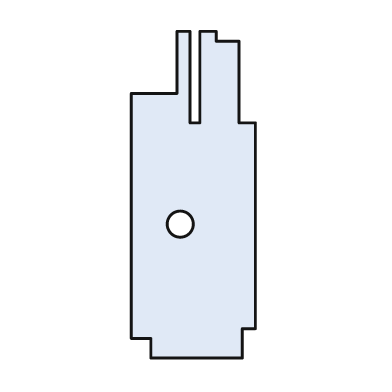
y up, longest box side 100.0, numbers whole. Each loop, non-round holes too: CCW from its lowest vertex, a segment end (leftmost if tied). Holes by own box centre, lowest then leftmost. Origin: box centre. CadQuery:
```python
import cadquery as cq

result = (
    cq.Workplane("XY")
    .moveTo(-13.0, -50.0)
    .lineTo(15.0, -50.0)
    .lineTo(15.0, -41.0)
    .lineTo(19.0, -41.0)
    .lineTo(19.0, 22.0)
    .lineTo(14.0, 22.0)
    .lineTo(14.0, 47.0)
    .lineTo(7.0, 47.0)
    .lineTo(7.0, 50.0)
    .lineTo(2.0, 50.0)
    .lineTo(2.0, 22.0)
    .lineTo(-1.0, 22.0)
    .lineTo(-1.0, 50.0)
    .lineTo(-5.0, 50.0)
    .lineTo(-5.0, 31.0)
    .lineTo(-19.0, 31.0)
    .lineTo(-19.0, -44.0)
    .lineTo(-13.0, -44.0)
    .close()
    .moveTo(-4.0, -9.0)
    .circle(4.0)
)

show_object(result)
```